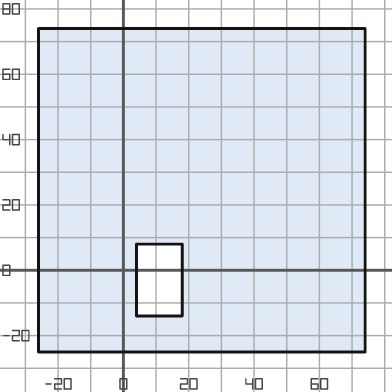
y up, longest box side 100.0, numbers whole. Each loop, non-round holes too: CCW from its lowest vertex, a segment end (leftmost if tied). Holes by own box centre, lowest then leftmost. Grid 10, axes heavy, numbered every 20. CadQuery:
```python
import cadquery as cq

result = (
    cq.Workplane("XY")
    .moveTo(-26.0, -25.0)
    .lineTo(74.0, -25.0)
    .lineTo(74.0, 74.0)
    .lineTo(-26.0, 74.0)
    .close()
    .moveTo(4.0, -14.0)
    .lineTo(18.0, -14.0)
    .lineTo(18.0, 8.0)
    .lineTo(4.0, 8.0)
    .close()
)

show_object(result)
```